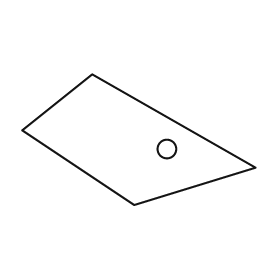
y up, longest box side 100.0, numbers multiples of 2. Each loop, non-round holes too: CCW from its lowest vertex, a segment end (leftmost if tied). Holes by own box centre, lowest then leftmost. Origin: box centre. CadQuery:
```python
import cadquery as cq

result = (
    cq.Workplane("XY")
    .moveTo(-2.0, -28.0)
    .lineTo(50.0, -12.0)
    .lineTo(-20.0, 28.0)
    .lineTo(-50.0, 4.0)
    .close()
    .moveTo(12.0, -4.0)
    .circle(4.0)
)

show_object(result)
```